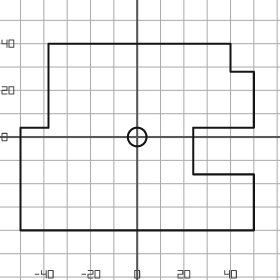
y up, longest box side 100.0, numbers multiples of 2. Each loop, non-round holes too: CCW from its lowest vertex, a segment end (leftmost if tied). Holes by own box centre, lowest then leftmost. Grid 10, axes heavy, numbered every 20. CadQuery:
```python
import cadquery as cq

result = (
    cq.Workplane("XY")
    .moveTo(-50.0, -40.0)
    .lineTo(50.0, -40.0)
    .lineTo(50.0, -16.0)
    .lineTo(24.0, -16.0)
    .lineTo(24.0, 4.0)
    .lineTo(50.0, 4.0)
    .lineTo(50.0, 28.0)
    .lineTo(40.0, 28.0)
    .lineTo(40.0, 40.0)
    .lineTo(-38.0, 40.0)
    .lineTo(-38.0, 4.0)
    .lineTo(-50.0, 4.0)
    .close()
    .moveTo(0.0, 0.0)
    .circle(4.0)
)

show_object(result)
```